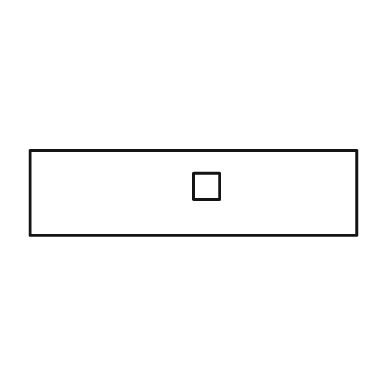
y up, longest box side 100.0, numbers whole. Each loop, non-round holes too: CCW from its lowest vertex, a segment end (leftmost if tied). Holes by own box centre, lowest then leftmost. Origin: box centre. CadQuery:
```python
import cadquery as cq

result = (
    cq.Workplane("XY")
    .moveTo(-50.0, -13.0)
    .lineTo(50.0, -13.0)
    .lineTo(50.0, 13.0)
    .lineTo(-50.0, 13.0)
    .close()
    .moveTo(0.0, -2.0)
    .lineTo(8.0, -2.0)
    .lineTo(8.0, 6.0)
    .lineTo(0.0, 6.0)
    .close()
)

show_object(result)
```